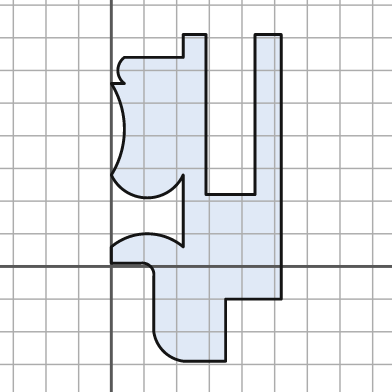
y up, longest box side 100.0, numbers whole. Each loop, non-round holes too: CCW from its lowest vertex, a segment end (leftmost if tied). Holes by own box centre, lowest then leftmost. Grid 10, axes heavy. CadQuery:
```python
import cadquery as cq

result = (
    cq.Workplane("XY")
    .moveTo(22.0, -29.0)
    .lineTo(35.0, -29.0)
    .lineTo(35.0, -10.0)
    .lineTo(52.0, -10.0)
    .lineTo(52.0, 71.0)
    .lineTo(44.0, 71.0)
    .lineTo(44.0, 22.0)
    .lineTo(29.0, 22.0)
    .lineTo(29.0, 71.0)
    .lineTo(22.0, 71.0)
    .lineTo(22.0, 64.0)
    .lineTo(4.0, 64.0)
    .threePointArc((2.0, 60.0), (4.0, 56.0))
    .lineTo(0.0, 56.0)
    .threePointArc((4.0, 42.0), (0.0, 28.0))
    .threePointArc((11.0, 21.0), (22.0, 28.0))
    .lineTo(22.0, 6.0)
    .threePointArc((11.0, 10.0), (0.0, 6.0))
    .lineTo(0.0, 1.0)
    .lineTo(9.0, 1.0)
    .threePointArc((12.0, 0.0), (13.0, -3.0))
    .lineTo(13.0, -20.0)
    .threePointArc((16.0, -26.0), (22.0, -29.0))
    .close()
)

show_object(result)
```